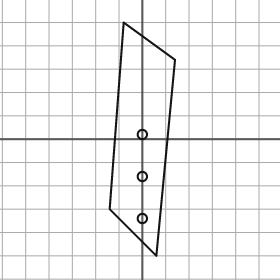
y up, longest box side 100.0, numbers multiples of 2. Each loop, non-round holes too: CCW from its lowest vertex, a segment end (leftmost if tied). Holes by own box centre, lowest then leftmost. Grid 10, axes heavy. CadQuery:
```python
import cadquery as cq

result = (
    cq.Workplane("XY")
    .moveTo(6.0, -50.0)
    .lineTo(14.0, 34.0)
    .lineTo(-8.0, 50.0)
    .lineTo(-14.0, -30.0)
    .close()
    .moveTo(0.0, -34.0)
    .circle(2.0)
    .moveTo(0.0, -16.0)
    .circle(2.0)
    .moveTo(0.0, 2.0)
    .circle(2.0)
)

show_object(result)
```